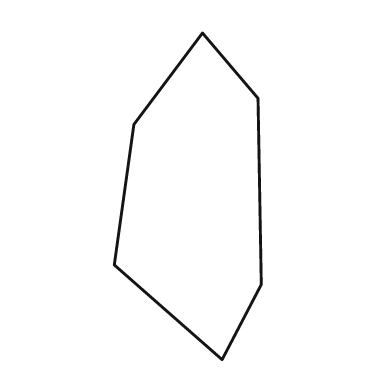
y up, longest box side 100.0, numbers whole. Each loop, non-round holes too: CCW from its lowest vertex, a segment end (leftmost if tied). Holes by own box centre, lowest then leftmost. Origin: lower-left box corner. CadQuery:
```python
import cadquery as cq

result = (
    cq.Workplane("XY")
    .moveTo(33.0, 0.0)
    .lineTo(45.0, 23.0)
    .lineTo(44.0, 80.0)
    .lineTo(27.0, 100.0)
    .lineTo(6.0, 72.0)
    .lineTo(0.0, 29.0)
    .close()
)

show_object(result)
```